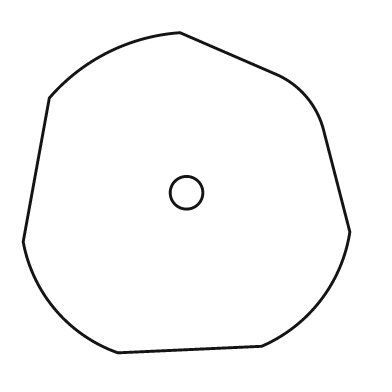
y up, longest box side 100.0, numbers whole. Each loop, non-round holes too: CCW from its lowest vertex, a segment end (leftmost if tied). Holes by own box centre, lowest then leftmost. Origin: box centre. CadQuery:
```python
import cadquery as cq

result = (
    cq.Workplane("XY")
    .moveTo(-21.0, -49.0)
    .lineTo(23.0, -47.0)
    .threePointArc((41.0, -33.0), (50.0, -12.0))
    .lineTo(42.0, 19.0)
    .threePointArc((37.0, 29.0), (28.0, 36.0))
    .lineTo(-2.0, 49.0)
    .threePointArc((-24.0, 43.0), (-42.0, 29.0))
    .lineTo(-50.0, -15.0)
    .threePointArc((-40.0, -36.0), (-21.0, -49.0))
    .close()
    .moveTo(0.0, 0.0)
    .circle(5.0)
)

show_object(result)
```